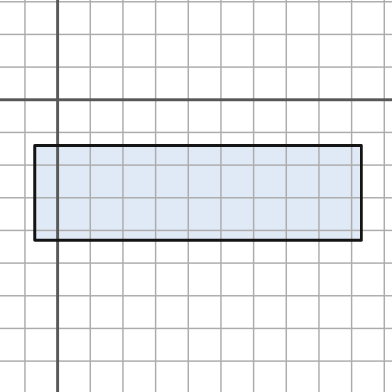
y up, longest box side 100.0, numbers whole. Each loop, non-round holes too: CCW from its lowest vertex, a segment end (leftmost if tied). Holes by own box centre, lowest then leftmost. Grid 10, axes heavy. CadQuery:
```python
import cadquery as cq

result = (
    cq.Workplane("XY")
    .moveTo(-7.0, -43.0)
    .lineTo(93.0, -43.0)
    .lineTo(93.0, -14.0)
    .lineTo(-7.0, -14.0)
    .close()
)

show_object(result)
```